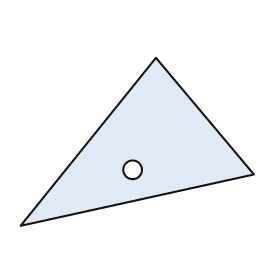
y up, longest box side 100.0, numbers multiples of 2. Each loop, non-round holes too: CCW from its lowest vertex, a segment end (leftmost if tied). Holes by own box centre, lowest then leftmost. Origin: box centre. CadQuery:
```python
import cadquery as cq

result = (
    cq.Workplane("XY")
    .moveTo(-50.0, -36.0)
    .lineTo(50.0, -14.0)
    .lineTo(8.0, 36.0)
    .close()
    .moveTo(-2.0, -12.0)
    .circle(4.0)
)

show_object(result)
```